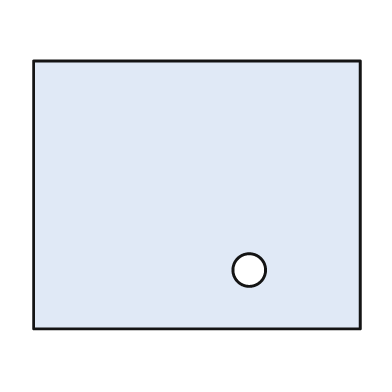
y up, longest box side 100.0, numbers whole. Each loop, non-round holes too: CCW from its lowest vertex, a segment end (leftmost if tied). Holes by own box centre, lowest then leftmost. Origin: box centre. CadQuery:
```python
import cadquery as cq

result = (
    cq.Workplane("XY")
    .moveTo(-50.0, -41.0)
    .lineTo(50.0, -41.0)
    .lineTo(50.0, 41.0)
    .lineTo(-50.0, 41.0)
    .close()
    .moveTo(16.0, -23.0)
    .circle(5.0)
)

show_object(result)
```